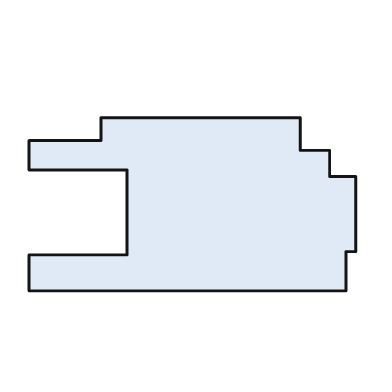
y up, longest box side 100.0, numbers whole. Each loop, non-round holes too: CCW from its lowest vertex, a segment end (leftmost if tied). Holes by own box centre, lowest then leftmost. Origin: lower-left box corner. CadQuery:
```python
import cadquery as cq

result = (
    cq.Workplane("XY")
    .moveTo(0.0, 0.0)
    .lineTo(97.0, 0.0)
    .lineTo(97.0, 12.0)
    .lineTo(100.0, 12.0)
    .lineTo(100.0, 35.0)
    .lineTo(92.0, 35.0)
    .lineTo(92.0, 43.0)
    .lineTo(83.0, 43.0)
    .lineTo(83.0, 53.0)
    .lineTo(22.0, 53.0)
    .lineTo(22.0, 46.0)
    .lineTo(0.0, 46.0)
    .lineTo(0.0, 37.0)
    .lineTo(30.0, 37.0)
    .lineTo(30.0, 11.0)
    .lineTo(0.0, 11.0)
    .close()
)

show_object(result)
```